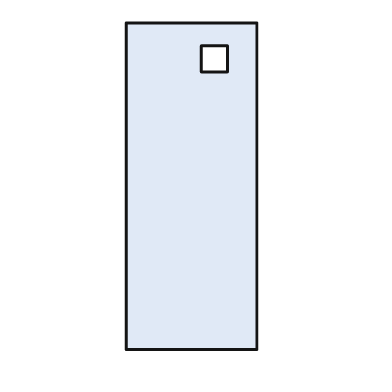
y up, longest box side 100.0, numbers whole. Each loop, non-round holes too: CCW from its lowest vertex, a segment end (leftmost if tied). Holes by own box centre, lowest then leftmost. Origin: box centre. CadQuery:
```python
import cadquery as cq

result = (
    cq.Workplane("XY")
    .moveTo(-20.0, -50.0)
    .lineTo(20.0, -50.0)
    .lineTo(20.0, 50.0)
    .lineTo(-20.0, 50.0)
    .close()
    .moveTo(3.0, 35.0)
    .lineTo(11.0, 35.0)
    .lineTo(11.0, 43.0)
    .lineTo(3.0, 43.0)
    .close()
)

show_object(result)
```